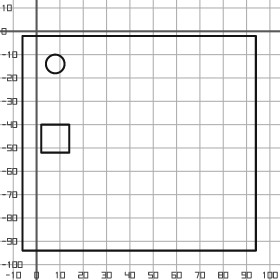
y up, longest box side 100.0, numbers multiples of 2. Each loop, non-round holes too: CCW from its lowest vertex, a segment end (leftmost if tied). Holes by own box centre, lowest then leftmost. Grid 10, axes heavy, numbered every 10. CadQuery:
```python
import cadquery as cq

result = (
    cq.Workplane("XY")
    .moveTo(-6.0, -94.0)
    .lineTo(94.0, -94.0)
    .lineTo(94.0, -2.0)
    .lineTo(-6.0, -2.0)
    .close()
    .moveTo(2.0, -52.0)
    .lineTo(14.0, -52.0)
    .lineTo(14.0, -40.0)
    .lineTo(2.0, -40.0)
    .close()
    .moveTo(8.0, -14.0)
    .circle(4.0)
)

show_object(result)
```